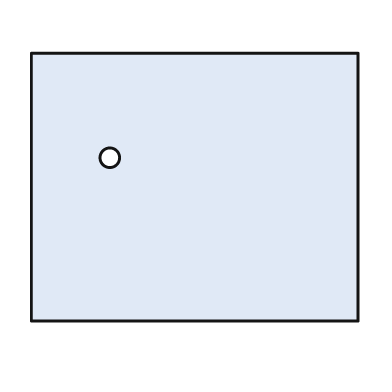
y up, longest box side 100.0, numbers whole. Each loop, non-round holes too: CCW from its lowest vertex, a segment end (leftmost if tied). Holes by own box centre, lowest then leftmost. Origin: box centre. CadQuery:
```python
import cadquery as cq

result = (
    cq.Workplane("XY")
    .moveTo(-50.0, -41.0)
    .lineTo(50.0, -41.0)
    .lineTo(50.0, 41.0)
    .lineTo(-50.0, 41.0)
    .close()
    .moveTo(-26.0, 9.0)
    .circle(3.0)
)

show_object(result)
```